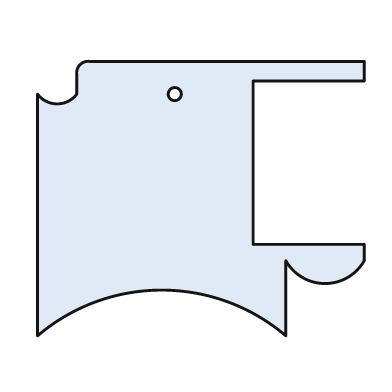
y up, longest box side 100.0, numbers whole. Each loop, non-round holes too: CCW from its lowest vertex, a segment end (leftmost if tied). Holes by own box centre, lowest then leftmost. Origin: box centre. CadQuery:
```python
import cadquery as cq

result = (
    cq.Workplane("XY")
    .moveTo(-50.0, -42.0)
    .threePointArc((-12.0, -28.0), (26.0, -42.0))
    .lineTo(26.0, -19.0)
    .threePointArc((38.0, -26.0), (50.0, -19.0))
    .lineTo(50.0, -14.0)
    .lineTo(16.0, -14.0)
    .lineTo(16.0, 36.0)
    .lineTo(50.0, 36.0)
    .lineTo(50.0, 42.0)
    .lineTo(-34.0, 42.0)
    .threePointArc((-37.0, 41.0), (-38.0, 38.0))
    .lineTo(-38.0, 32.0)
    .threePointArc((-44.0, 29.0), (-50.0, 32.0))
    .close()
    .moveTo(-8.0, 32.0)
    .circle(2.0)
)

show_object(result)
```